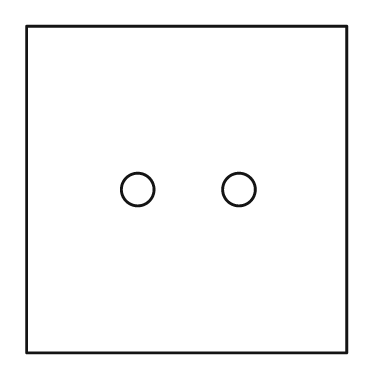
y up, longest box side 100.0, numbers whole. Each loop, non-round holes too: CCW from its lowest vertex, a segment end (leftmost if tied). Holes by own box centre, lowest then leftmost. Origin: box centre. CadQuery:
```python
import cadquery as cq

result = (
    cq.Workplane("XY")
    .moveTo(-49.0, -50.0)
    .lineTo(49.0, -50.0)
    .lineTo(49.0, 50.0)
    .lineTo(-49.0, 50.0)
    .close()
    .moveTo(-15.0, 0.0)
    .circle(5.0)
    .moveTo(16.0, 0.0)
    .circle(5.0)
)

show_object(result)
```